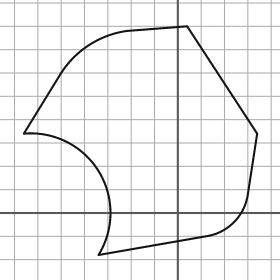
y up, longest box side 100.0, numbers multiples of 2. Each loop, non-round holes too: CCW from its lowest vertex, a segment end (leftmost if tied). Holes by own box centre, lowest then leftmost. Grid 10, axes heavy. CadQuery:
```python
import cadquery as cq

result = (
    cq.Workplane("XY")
    .moveTo(-34.0, -18.0)
    .lineTo(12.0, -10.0)
    .threePointArc((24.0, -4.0), (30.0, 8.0))
    .lineTo(34.0, 34.0)
    .lineTo(4.0, 80.0)
    .lineTo(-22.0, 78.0)
    .threePointArc((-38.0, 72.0), (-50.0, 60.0))
    .lineTo(-66.0, 34.0)
    .threePointArc((-34.0, 18.0), (-34.0, -18.0))
    .close()
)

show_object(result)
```